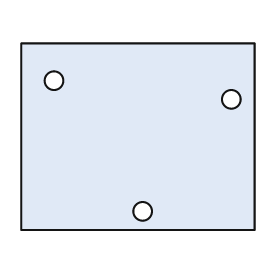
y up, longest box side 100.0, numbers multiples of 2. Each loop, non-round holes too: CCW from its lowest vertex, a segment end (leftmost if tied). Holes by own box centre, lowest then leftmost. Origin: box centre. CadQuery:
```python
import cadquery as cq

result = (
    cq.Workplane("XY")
    .moveTo(-50.0, -40.0)
    .lineTo(50.0, -40.0)
    .lineTo(50.0, 40.0)
    .lineTo(-50.0, 40.0)
    .close()
    .moveTo(2.0, -32.0)
    .circle(4.0)
    .moveTo(40.0, 16.0)
    .circle(4.0)
    .moveTo(-36.0, 24.0)
    .circle(4.0)
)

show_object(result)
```